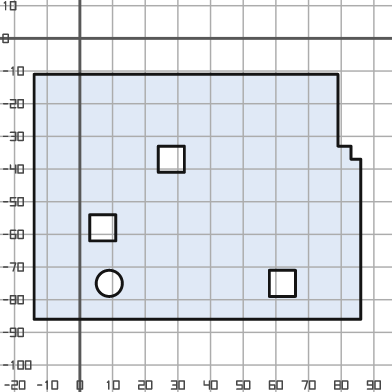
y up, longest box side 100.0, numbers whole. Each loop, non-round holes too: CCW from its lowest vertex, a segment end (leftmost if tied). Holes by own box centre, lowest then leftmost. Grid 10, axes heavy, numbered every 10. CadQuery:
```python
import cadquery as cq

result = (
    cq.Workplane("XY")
    .moveTo(-14.0, -86.0)
    .lineTo(86.0, -86.0)
    .lineTo(86.0, -37.0)
    .lineTo(83.0, -37.0)
    .lineTo(83.0, -33.0)
    .lineTo(79.0, -33.0)
    .lineTo(79.0, -11.0)
    .lineTo(-14.0, -11.0)
    .close()
    .moveTo(9.0, -75.0)
    .circle(4.0)
    .moveTo(58.0, -79.0)
    .lineTo(66.0, -79.0)
    .lineTo(66.0, -71.0)
    .lineTo(58.0, -71.0)
    .close()
    .moveTo(3.0, -62.0)
    .lineTo(11.0, -62.0)
    .lineTo(11.0, -54.0)
    .lineTo(3.0, -54.0)
    .close()
    .moveTo(24.0, -41.0)
    .lineTo(32.0, -41.0)
    .lineTo(32.0, -33.0)
    .lineTo(24.0, -33.0)
    .close()
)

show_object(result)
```